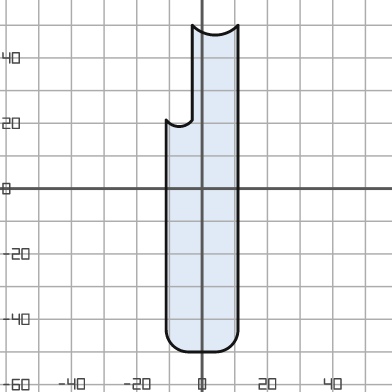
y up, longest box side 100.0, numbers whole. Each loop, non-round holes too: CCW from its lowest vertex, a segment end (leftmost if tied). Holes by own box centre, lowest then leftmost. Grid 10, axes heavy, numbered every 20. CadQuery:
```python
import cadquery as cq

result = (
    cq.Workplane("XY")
    .moveTo(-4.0, -50.0)
    .lineTo(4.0, -50.0)
    .threePointArc((9.0, -48.0), (11.0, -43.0))
    .lineTo(11.0, 50.0)
    .threePointArc((4.0, 47.0), (-3.0, 50.0))
    .lineTo(-3.0, 21.0)
    .threePointArc((-7.0, 19.0), (-11.0, 21.0))
    .lineTo(-11.0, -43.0)
    .threePointArc((-9.0, -48.0), (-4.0, -50.0))
    .close()
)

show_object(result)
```